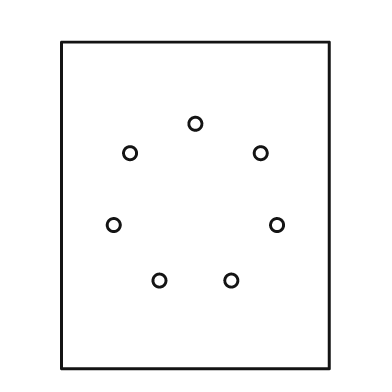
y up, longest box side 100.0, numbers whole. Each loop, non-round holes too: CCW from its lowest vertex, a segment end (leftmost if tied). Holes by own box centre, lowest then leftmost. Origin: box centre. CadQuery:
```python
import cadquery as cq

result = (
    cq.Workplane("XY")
    .moveTo(-41.0, -50.0)
    .lineTo(41.0, -50.0)
    .lineTo(41.0, 50.0)
    .lineTo(-41.0, 50.0)
    .close()
    .moveTo(-11.0, -23.0)
    .circle(2.0)
    .moveTo(11.0, -23.0)
    .circle(2.0)
    .moveTo(-25.0, -6.0)
    .circle(2.0)
    .moveTo(25.0, -6.0)
    .circle(2.0)
    .moveTo(-20.0, 16.0)
    .circle(2.0)
    .moveTo(20.0, 16.0)
    .circle(2.0)
    .moveTo(0.0, 25.0)
    .circle(2.0)
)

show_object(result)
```